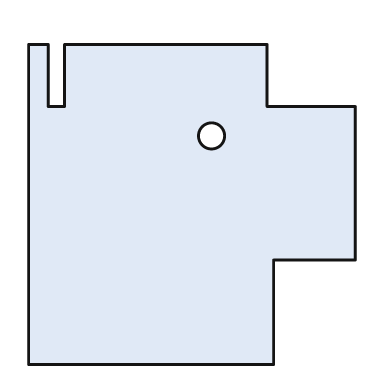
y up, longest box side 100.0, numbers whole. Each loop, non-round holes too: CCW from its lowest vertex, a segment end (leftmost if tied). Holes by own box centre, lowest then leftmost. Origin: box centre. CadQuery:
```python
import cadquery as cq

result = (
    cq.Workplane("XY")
    .moveTo(-50.0, -49.0)
    .lineTo(25.0, -49.0)
    .lineTo(25.0, -17.0)
    .lineTo(50.0, -17.0)
    .lineTo(50.0, 30.0)
    .lineTo(23.0, 30.0)
    .lineTo(23.0, 49.0)
    .lineTo(-39.0, 49.0)
    .lineTo(-39.0, 30.0)
    .lineTo(-44.0, 30.0)
    .lineTo(-44.0, 49.0)
    .lineTo(-50.0, 49.0)
    .close()
    .moveTo(6.0, 21.0)
    .circle(4.0)
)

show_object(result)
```